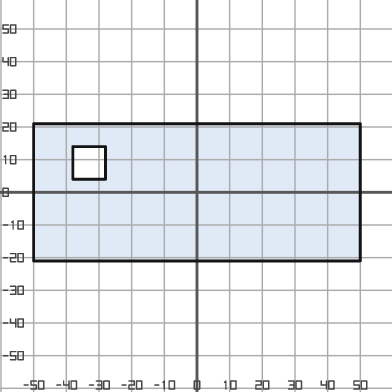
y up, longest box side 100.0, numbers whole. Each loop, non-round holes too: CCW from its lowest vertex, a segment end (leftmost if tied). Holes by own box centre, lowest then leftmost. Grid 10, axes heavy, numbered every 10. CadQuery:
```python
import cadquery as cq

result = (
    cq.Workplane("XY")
    .moveTo(-50.0, -21.0)
    .lineTo(50.0, -21.0)
    .lineTo(50.0, 21.0)
    .lineTo(-50.0, 21.0)
    .close()
    .moveTo(-38.0, 4.0)
    .lineTo(-28.0, 4.0)
    .lineTo(-28.0, 14.0)
    .lineTo(-38.0, 14.0)
    .close()
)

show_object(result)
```